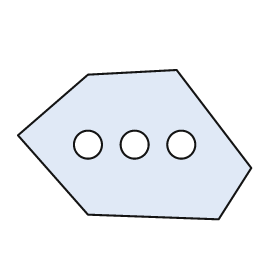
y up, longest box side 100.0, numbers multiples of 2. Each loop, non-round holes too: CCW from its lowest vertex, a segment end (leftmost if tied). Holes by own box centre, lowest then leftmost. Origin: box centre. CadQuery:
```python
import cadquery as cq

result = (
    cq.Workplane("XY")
    .moveTo(36.0, -32.0)
    .lineTo(50.0, -10.0)
    .lineTo(18.0, 32.0)
    .lineTo(-20.0, 30.0)
    .lineTo(-50.0, 4.0)
    .lineTo(-20.0, -30.0)
    .close()
    .moveTo(-20.0, 0.0)
    .circle(6.0)
    .moveTo(0.0, 0.0)
    .circle(6.0)
    .moveTo(20.0, 0.0)
    .circle(6.0)
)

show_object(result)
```